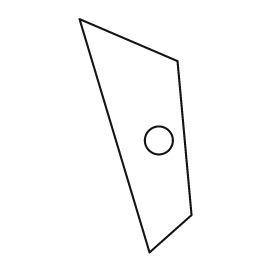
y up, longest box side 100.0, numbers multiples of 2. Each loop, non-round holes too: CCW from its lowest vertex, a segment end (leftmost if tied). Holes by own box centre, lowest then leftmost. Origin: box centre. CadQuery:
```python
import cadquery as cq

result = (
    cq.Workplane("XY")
    .moveTo(6.0, -50.0)
    .lineTo(24.0, -34.0)
    .lineTo(18.0, 32.0)
    .lineTo(-24.0, 50.0)
    .close()
    .moveTo(10.0, -2.0)
    .circle(6.0)
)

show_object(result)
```